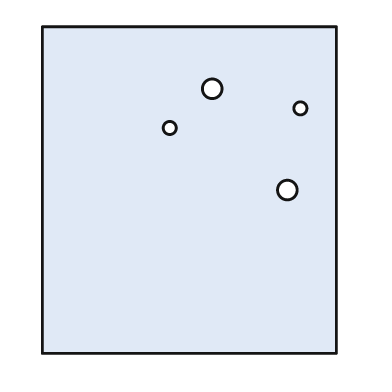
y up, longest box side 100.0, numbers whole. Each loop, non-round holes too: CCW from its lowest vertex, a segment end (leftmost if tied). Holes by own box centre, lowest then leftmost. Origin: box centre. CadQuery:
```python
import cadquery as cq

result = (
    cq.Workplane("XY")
    .moveTo(-45.0, -50.0)
    .lineTo(45.0, -50.0)
    .lineTo(45.0, 50.0)
    .lineTo(-45.0, 50.0)
    .close()
    .moveTo(30.0, 0.0)
    .circle(3.0)
    .moveTo(-6.0, 19.0)
    .circle(2.0)
    .moveTo(34.0, 25.0)
    .circle(2.0)
    .moveTo(7.0, 31.0)
    .circle(3.0)
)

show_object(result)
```